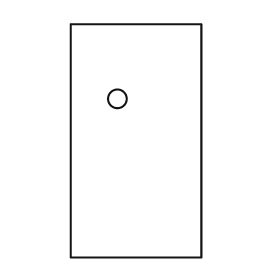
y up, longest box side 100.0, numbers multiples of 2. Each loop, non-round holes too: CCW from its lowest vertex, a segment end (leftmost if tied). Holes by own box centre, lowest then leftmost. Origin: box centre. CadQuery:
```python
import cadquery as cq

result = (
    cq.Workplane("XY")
    .moveTo(-28.0, -50.0)
    .lineTo(28.0, -50.0)
    .lineTo(28.0, 50.0)
    .lineTo(-28.0, 50.0)
    .close()
    .moveTo(-8.0, 18.0)
    .circle(4.0)
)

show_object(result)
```